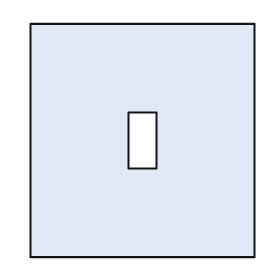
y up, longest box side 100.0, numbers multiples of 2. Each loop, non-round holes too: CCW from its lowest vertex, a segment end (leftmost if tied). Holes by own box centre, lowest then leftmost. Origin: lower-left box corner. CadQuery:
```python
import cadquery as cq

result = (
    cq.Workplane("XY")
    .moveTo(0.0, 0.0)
    .lineTo(96.0, 0.0)
    .lineTo(96.0, 100.0)
    .lineTo(0.0, 100.0)
    .close()
    .moveTo(42.0, 38.0)
    .lineTo(54.0, 38.0)
    .lineTo(54.0, 62.0)
    .lineTo(42.0, 62.0)
    .close()
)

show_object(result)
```